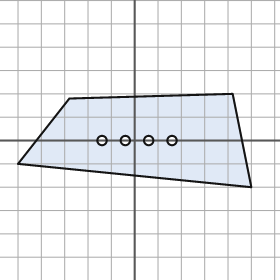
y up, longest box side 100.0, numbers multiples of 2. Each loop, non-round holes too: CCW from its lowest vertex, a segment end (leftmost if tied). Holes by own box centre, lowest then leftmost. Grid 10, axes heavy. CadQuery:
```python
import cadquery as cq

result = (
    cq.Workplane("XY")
    .moveTo(50.0, -20.0)
    .lineTo(42.0, 20.0)
    .lineTo(-28.0, 18.0)
    .lineTo(-50.0, -10.0)
    .close()
    .moveTo(-14.0, 0.0)
    .circle(2.0)
    .moveTo(-4.0, 0.0)
    .circle(2.0)
    .moveTo(6.0, 0.0)
    .circle(2.0)
    .moveTo(16.0, 0.0)
    .circle(2.0)
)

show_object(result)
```